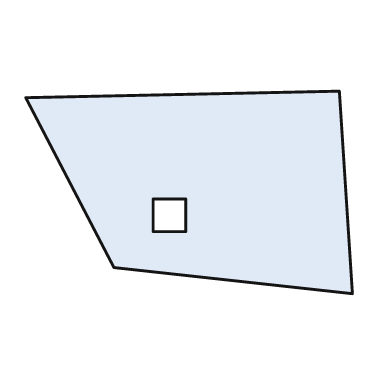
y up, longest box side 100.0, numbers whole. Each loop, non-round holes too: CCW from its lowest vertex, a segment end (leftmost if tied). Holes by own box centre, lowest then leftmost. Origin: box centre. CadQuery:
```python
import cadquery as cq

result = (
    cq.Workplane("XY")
    .moveTo(50.0, -31.0)
    .lineTo(46.0, 31.0)
    .lineTo(-50.0, 29.0)
    .lineTo(-23.0, -23.0)
    .close()
    .moveTo(-11.0, -12.0)
    .lineTo(-1.0, -12.0)
    .lineTo(-1.0, -2.0)
    .lineTo(-11.0, -2.0)
    .close()
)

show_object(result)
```